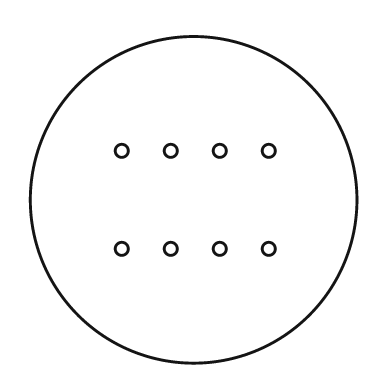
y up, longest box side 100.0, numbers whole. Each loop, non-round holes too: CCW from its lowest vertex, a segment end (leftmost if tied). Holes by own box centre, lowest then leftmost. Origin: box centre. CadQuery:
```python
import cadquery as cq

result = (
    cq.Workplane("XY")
    .moveTo(0.0, 0.0)
    .circle(50.0)
    .moveTo(-22.0, -15.0)
    .circle(2.0)
    .moveTo(-7.0, -15.0)
    .circle(2.0)
    .moveTo(8.0, -15.0)
    .circle(2.0)
    .moveTo(23.0, -15.0)
    .circle(2.0)
    .moveTo(-22.0, 15.0)
    .circle(2.0)
    .moveTo(-7.0, 15.0)
    .circle(2.0)
    .moveTo(8.0, 15.0)
    .circle(2.0)
    .moveTo(23.0, 15.0)
    .circle(2.0)
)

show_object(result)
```